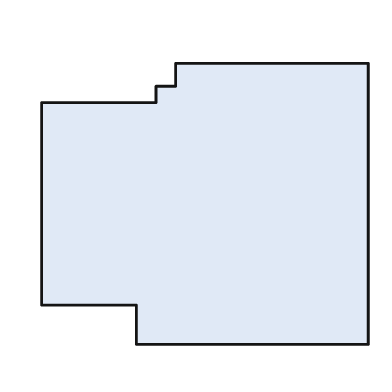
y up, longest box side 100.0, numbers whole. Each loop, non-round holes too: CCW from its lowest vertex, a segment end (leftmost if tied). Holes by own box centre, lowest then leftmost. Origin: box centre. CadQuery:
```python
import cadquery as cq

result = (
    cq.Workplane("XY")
    .moveTo(-21.0, -43.0)
    .lineTo(50.0, -43.0)
    .lineTo(50.0, 43.0)
    .lineTo(-9.0, 43.0)
    .lineTo(-9.0, 36.0)
    .lineTo(-15.0, 36.0)
    .lineTo(-15.0, 31.0)
    .lineTo(-50.0, 31.0)
    .lineTo(-50.0, -31.0)
    .lineTo(-21.0, -31.0)
    .close()
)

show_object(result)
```